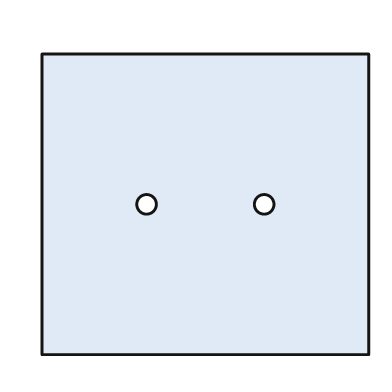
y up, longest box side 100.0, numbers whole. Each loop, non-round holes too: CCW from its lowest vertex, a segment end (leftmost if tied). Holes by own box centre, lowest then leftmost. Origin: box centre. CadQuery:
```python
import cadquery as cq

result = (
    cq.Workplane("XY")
    .moveTo(-50.0, -46.0)
    .lineTo(50.0, -46.0)
    .lineTo(50.0, 46.0)
    .lineTo(-50.0, 46.0)
    .close()
    .moveTo(-18.0, 0.0)
    .circle(3.0)
    .moveTo(18.0, 0.0)
    .circle(3.0)
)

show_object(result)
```